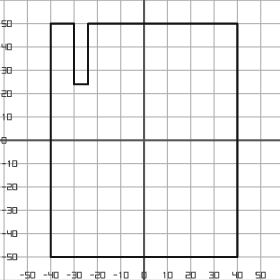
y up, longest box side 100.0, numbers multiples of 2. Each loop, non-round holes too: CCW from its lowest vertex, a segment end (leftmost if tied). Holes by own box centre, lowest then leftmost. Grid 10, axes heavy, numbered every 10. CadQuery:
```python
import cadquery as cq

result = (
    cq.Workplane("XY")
    .moveTo(-40.0, -50.0)
    .lineTo(40.0, -50.0)
    .lineTo(40.0, 50.0)
    .lineTo(-24.0, 50.0)
    .lineTo(-24.0, 24.0)
    .lineTo(-30.0, 24.0)
    .lineTo(-30.0, 50.0)
    .lineTo(-40.0, 50.0)
    .close()
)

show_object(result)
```